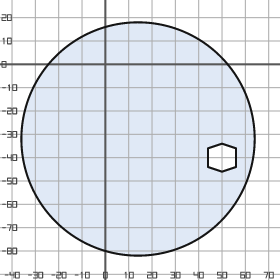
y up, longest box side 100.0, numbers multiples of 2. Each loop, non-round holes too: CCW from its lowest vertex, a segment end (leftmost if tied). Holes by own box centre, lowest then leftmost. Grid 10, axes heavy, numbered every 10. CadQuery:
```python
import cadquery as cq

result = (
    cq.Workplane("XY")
    .moveTo(14.0, -32.0)
    .circle(50.0)
    .moveTo(50.0, -46.0)
    .lineTo(56.0, -44.0)
    .lineTo(56.0, -36.0)
    .lineTo(50.0, -34.0)
    .lineTo(44.0, -36.0)
    .lineTo(44.0, -44.0)
    .close()
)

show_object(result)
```